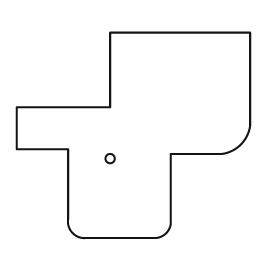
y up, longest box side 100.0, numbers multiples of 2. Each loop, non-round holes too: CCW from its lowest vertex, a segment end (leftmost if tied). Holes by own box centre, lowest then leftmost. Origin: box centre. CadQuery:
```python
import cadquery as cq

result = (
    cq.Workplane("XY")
    .moveTo(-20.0, -44.0)
    .lineTo(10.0, -44.0)
    .threePointArc((14.0, -42.0), (16.0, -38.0))
    .lineTo(16.0, -8.0)
    .lineTo(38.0, -8.0)
    .threePointArc((46.0, -4.0), (50.0, 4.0))
    .lineTo(50.0, 44.0)
    .lineTo(-10.0, 44.0)
    .lineTo(-10.0, 12.0)
    .lineTo(-50.0, 12.0)
    .lineTo(-50.0, -6.0)
    .lineTo(-28.0, -6.0)
    .lineTo(-28.0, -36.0)
    .threePointArc((-26.0, -42.0), (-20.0, -44.0))
    .close()
    .moveTo(-10.0, -10.0)
    .circle(2.0)
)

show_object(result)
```